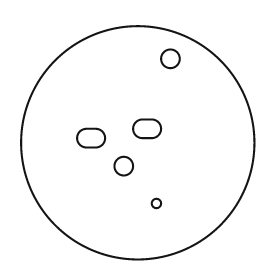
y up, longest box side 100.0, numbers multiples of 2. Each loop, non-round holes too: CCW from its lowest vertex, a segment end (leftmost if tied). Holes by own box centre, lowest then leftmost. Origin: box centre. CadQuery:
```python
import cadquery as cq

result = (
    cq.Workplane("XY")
    .moveTo(0.0, 0.0)
    .circle(50.0)
    .moveTo(8.0, -26.0)
    .circle(2.0)
    .moveTo(-6.0, -10.0)
    .circle(4.0)
    .moveTo(-22.0, -2.0)
    .lineTo(-18.0, -2.0)
    .threePointArc((-14.0, 2.0), (-18.0, 6.0))
    .lineTo(-22.0, 6.0)
    .threePointArc((-26.0, 2.0), (-22.0, -2.0))
    .close()
    .moveTo(2.0, 2.0)
    .lineTo(6.0, 2.0)
    .threePointArc((10.0, 6.0), (6.0, 10.0))
    .lineTo(2.0, 10.0)
    .threePointArc((-2.0, 6.0), (2.0, 2.0))
    .close()
    .moveTo(14.0, 36.0)
    .circle(4.0)
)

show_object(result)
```